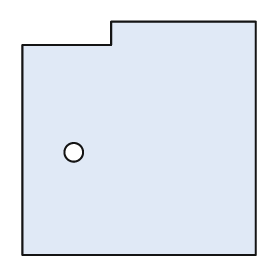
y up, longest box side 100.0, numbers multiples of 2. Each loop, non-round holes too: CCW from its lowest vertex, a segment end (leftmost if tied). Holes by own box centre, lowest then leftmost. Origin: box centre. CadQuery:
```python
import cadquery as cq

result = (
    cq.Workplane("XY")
    .moveTo(-50.0, -50.0)
    .lineTo(50.0, -50.0)
    .lineTo(50.0, 50.0)
    .lineTo(-12.0, 50.0)
    .lineTo(-12.0, 40.0)
    .lineTo(-50.0, 40.0)
    .close()
    .moveTo(-28.0, -6.0)
    .circle(4.0)
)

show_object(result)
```